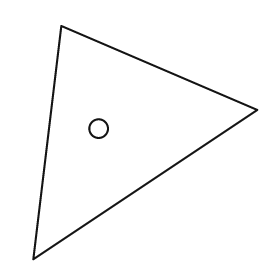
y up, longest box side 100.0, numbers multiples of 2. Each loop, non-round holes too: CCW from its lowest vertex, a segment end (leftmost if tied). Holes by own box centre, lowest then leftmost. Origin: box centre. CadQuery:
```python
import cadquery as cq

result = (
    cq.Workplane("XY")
    .moveTo(-48.0, -50.0)
    .lineTo(48.0, 14.0)
    .lineTo(-36.0, 50.0)
    .close()
    .moveTo(-20.0, 6.0)
    .circle(4.0)
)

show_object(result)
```